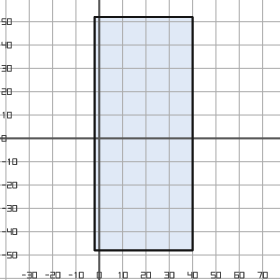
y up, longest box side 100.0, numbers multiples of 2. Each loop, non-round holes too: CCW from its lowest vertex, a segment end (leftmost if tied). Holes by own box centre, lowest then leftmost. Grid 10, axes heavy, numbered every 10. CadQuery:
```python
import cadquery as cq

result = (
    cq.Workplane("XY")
    .moveTo(-2.0, -48.0)
    .lineTo(40.0, -48.0)
    .lineTo(40.0, 52.0)
    .lineTo(-2.0, 52.0)
    .close()
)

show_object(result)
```